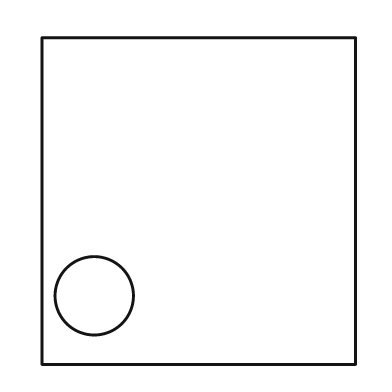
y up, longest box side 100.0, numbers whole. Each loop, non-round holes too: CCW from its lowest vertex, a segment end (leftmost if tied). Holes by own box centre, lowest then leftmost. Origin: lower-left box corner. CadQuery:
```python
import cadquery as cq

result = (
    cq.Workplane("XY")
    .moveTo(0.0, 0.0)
    .lineTo(96.0, 0.0)
    .lineTo(96.0, 100.0)
    .lineTo(0.0, 100.0)
    .close()
    .moveTo(16.0, 21.0)
    .circle(12.0)
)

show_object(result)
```